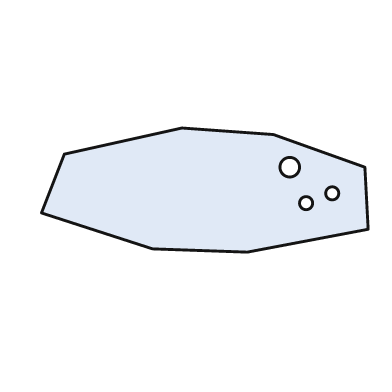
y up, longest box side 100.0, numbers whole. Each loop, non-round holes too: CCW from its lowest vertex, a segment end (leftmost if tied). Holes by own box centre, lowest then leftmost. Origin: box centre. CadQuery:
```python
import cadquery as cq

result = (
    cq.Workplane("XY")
    .moveTo(13.0, -19.0)
    .lineTo(50.0, -12.0)
    .lineTo(49.0, 7.0)
    .lineTo(21.0, 17.0)
    .lineTo(-7.0, 19.0)
    .lineTo(-43.0, 11.0)
    .lineTo(-50.0, -7.0)
    .lineTo(-16.0, -18.0)
    .close()
    .moveTo(31.0, -4.0)
    .circle(2.0)
    .moveTo(39.0, -1.0)
    .circle(2.0)
    .moveTo(26.0, 7.0)
    .circle(3.0)
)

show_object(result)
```